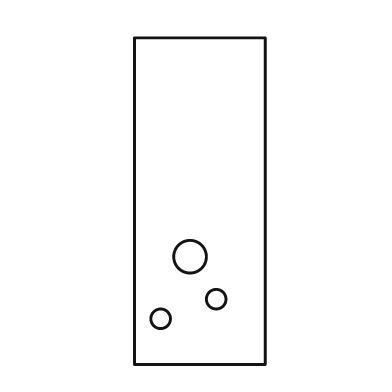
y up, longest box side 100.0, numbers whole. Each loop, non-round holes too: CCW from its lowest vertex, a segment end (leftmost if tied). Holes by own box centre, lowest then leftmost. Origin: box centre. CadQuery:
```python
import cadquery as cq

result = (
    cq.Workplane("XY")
    .moveTo(-20.0, -50.0)
    .lineTo(20.0, -50.0)
    .lineTo(20.0, 50.0)
    .lineTo(-20.0, 50.0)
    .close()
    .moveTo(-12.0, -36.0)
    .circle(3.0)
    .moveTo(5.0, -30.0)
    .circle(3.0)
    .moveTo(-3.0, -17.0)
    .circle(5.0)
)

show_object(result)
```